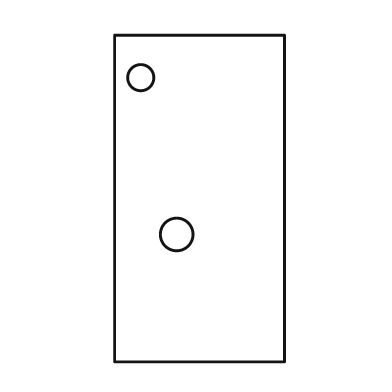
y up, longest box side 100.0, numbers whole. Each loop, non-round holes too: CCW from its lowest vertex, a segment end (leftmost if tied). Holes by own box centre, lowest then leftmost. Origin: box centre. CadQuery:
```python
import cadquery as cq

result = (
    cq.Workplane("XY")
    .moveTo(-26.0, -50.0)
    .lineTo(26.0, -50.0)
    .lineTo(26.0, 50.0)
    .lineTo(-26.0, 50.0)
    .close()
    .moveTo(-7.0, -11.0)
    .circle(5.0)
    .moveTo(-18.0, 37.0)
    .circle(4.0)
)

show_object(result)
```